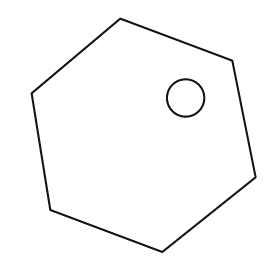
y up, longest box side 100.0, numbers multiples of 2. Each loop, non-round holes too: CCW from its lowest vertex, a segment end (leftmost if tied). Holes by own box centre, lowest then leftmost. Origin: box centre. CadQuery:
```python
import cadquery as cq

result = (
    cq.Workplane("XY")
    .moveTo(8.0, -50.0)
    .lineTo(48.0, -18.0)
    .lineTo(38.0, 32.0)
    .lineTo(-10.0, 50.0)
    .lineTo(-48.0, 18.0)
    .lineTo(-40.0, -32.0)
    .close()
    .moveTo(18.0, 16.0)
    .circle(8.0)
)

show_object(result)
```